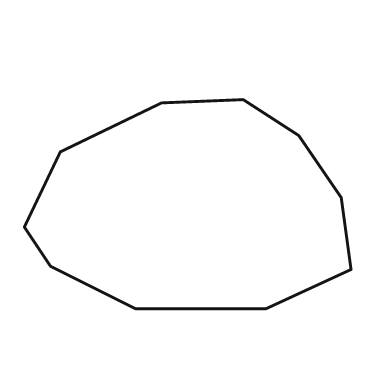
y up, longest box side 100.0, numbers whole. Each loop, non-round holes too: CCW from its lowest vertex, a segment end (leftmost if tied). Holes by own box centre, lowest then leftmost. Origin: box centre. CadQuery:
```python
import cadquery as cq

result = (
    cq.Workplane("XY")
    .moveTo(-16.0, -32.0)
    .lineTo(24.0, -32.0)
    .lineTo(50.0, -20.0)
    .lineTo(47.0, 2.0)
    .lineTo(34.0, 21.0)
    .lineTo(17.0, 32.0)
    .lineTo(-8.0, 31.0)
    .lineTo(-39.0, 16.0)
    .lineTo(-50.0, -7.0)
    .lineTo(-42.0, -19.0)
    .close()
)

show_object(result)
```